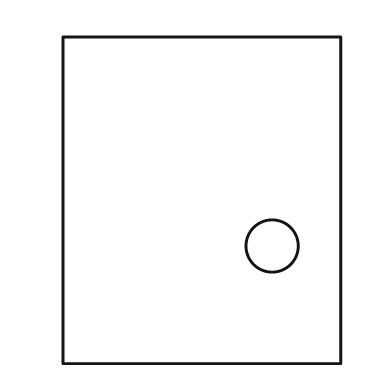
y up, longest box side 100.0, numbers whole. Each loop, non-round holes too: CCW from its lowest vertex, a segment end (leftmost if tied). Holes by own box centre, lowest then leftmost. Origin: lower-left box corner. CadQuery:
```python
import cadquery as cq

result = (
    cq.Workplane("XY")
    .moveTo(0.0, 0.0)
    .lineTo(85.0, 0.0)
    .lineTo(85.0, 100.0)
    .lineTo(0.0, 100.0)
    .close()
    .moveTo(64.0, 36.0)
    .circle(8.0)
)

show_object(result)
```